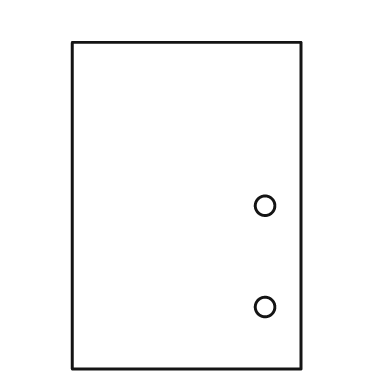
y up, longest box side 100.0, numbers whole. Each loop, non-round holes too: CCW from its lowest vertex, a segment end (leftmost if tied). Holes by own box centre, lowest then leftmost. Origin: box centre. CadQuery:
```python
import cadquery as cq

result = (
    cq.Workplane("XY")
    .moveTo(-35.0, -50.0)
    .lineTo(35.0, -50.0)
    .lineTo(35.0, 50.0)
    .lineTo(-35.0, 50.0)
    .close()
    .moveTo(24.0, -31.0)
    .circle(3.0)
    .moveTo(24.0, 0.0)
    .circle(3.0)
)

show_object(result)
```